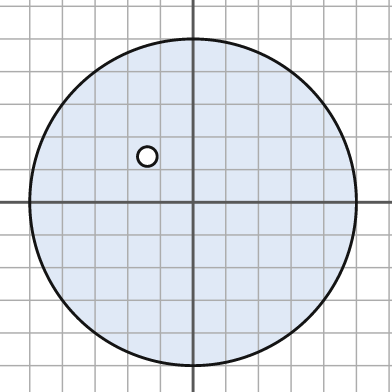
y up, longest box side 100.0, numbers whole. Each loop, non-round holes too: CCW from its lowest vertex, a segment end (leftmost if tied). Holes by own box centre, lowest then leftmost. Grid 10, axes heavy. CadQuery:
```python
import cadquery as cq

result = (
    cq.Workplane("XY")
    .moveTo(0.0, 0.0)
    .circle(50.0)
    .moveTo(-14.0, 14.0)
    .circle(3.0)
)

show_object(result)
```